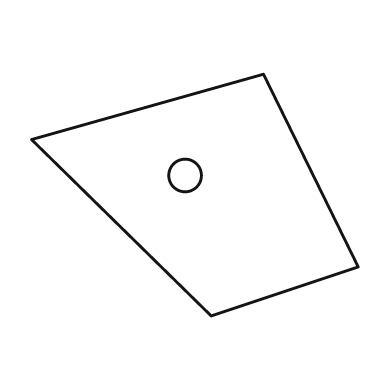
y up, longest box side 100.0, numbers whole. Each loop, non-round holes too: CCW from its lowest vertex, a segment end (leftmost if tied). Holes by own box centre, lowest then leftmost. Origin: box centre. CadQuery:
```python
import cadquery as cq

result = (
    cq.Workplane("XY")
    .moveTo(5.0, -37.0)
    .lineTo(50.0, -22.0)
    .lineTo(21.0, 37.0)
    .lineTo(-50.0, 17.0)
    .close()
    .moveTo(-3.0, 6.0)
    .circle(5.0)
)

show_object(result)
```